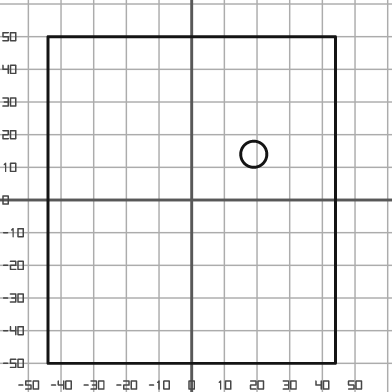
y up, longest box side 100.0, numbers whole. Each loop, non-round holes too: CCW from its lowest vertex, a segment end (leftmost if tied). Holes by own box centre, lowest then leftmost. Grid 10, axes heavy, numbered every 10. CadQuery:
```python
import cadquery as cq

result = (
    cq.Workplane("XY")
    .moveTo(-44.0, -50.0)
    .lineTo(44.0, -50.0)
    .lineTo(44.0, 50.0)
    .lineTo(-44.0, 50.0)
    .close()
    .moveTo(19.0, 14.0)
    .circle(4.0)
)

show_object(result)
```